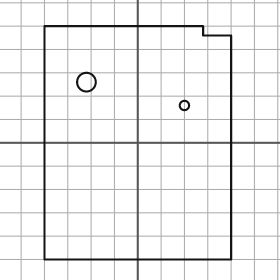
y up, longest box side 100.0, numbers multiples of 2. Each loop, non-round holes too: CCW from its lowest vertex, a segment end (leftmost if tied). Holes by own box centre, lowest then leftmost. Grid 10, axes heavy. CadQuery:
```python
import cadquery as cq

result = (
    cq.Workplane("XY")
    .moveTo(-40.0, -50.0)
    .lineTo(40.0, -50.0)
    .lineTo(40.0, 46.0)
    .lineTo(28.0, 46.0)
    .lineTo(28.0, 50.0)
    .lineTo(-40.0, 50.0)
    .close()
    .moveTo(20.0, 16.0)
    .circle(2.0)
    .moveTo(-22.0, 26.0)
    .circle(4.0)
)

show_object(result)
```